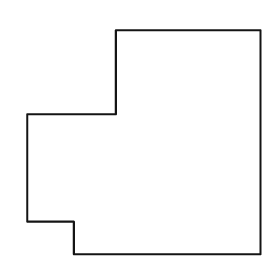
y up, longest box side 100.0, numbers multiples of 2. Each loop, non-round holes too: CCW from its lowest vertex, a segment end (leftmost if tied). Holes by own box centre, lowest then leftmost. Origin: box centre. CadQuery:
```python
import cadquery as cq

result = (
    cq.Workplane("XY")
    .moveTo(-30.0, -48.0)
    .lineTo(50.0, -48.0)
    .lineTo(50.0, 48.0)
    .lineTo(-12.0, 48.0)
    .lineTo(-12.0, 12.0)
    .lineTo(-50.0, 12.0)
    .lineTo(-50.0, -34.0)
    .lineTo(-30.0, -34.0)
    .close()
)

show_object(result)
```